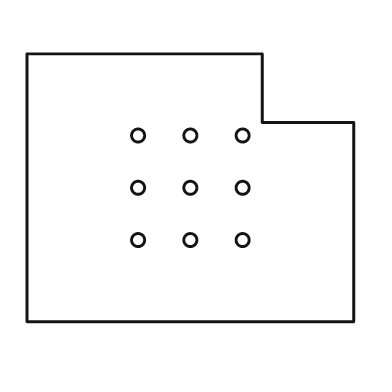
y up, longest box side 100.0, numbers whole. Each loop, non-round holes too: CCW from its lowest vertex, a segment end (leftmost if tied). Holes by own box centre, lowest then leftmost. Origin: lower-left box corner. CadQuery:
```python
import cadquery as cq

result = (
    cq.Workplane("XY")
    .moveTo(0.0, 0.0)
    .lineTo(100.0, 0.0)
    .lineTo(100.0, 61.0)
    .lineTo(72.0, 61.0)
    .lineTo(72.0, 82.0)
    .lineTo(0.0, 82.0)
    .close()
    .moveTo(34.0, 25.0)
    .circle(2.0)
    .moveTo(50.0, 25.0)
    .circle(2.0)
    .moveTo(66.0, 25.0)
    .circle(2.0)
    .moveTo(34.0, 41.0)
    .circle(2.0)
    .moveTo(50.0, 41.0)
    .circle(2.0)
    .moveTo(66.0, 41.0)
    .circle(2.0)
    .moveTo(34.0, 57.0)
    .circle(2.0)
    .moveTo(50.0, 57.0)
    .circle(2.0)
    .moveTo(66.0, 57.0)
    .circle(2.0)
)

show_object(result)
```